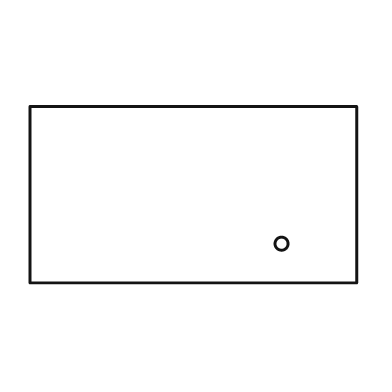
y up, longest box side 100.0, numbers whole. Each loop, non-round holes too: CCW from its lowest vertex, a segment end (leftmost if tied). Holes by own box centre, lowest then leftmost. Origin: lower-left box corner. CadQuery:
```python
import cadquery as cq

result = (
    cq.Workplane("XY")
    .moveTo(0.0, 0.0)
    .lineTo(100.0, 0.0)
    .lineTo(100.0, 54.0)
    .lineTo(0.0, 54.0)
    .close()
    .moveTo(77.0, 12.0)
    .circle(2.0)
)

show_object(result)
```